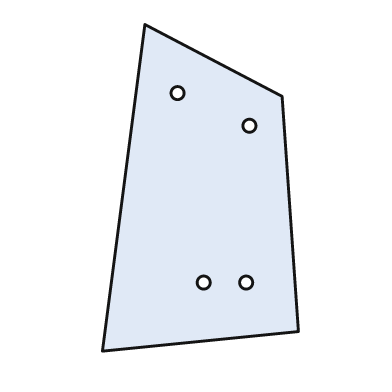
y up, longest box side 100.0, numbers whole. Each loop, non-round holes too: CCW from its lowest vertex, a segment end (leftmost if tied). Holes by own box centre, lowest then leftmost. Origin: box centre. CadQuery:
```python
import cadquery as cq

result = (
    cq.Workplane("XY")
    .moveTo(-30.0, -50.0)
    .lineTo(30.0, -44.0)
    .lineTo(25.0, 28.0)
    .lineTo(-17.0, 50.0)
    .close()
    .moveTo(1.0, -29.0)
    .circle(2.0)
    .moveTo(14.0, -29.0)
    .circle(2.0)
    .moveTo(15.0, 19.0)
    .circle(2.0)
    .moveTo(-7.0, 29.0)
    .circle(2.0)
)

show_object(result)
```